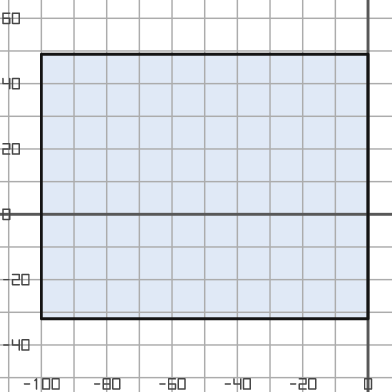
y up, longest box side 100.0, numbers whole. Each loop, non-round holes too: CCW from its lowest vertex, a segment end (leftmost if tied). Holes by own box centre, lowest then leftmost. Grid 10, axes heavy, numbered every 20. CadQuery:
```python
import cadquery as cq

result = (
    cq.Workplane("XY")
    .moveTo(-100.0, -32.0)
    .lineTo(0.0, -32.0)
    .lineTo(0.0, 49.0)
    .lineTo(-100.0, 49.0)
    .close()
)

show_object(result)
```